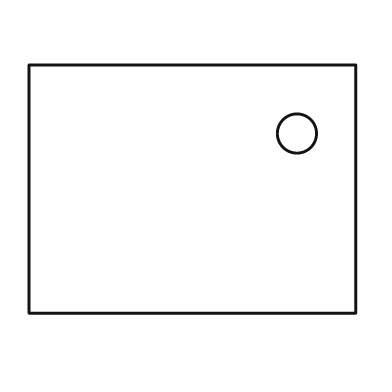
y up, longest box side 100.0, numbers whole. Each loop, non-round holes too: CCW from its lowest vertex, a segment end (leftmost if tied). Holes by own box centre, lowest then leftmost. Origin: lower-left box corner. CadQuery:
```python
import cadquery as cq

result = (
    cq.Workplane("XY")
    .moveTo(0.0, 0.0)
    .lineTo(100.0, 0.0)
    .lineTo(100.0, 76.0)
    .lineTo(0.0, 76.0)
    .close()
    .moveTo(82.0, 55.0)
    .circle(6.0)
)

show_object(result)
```